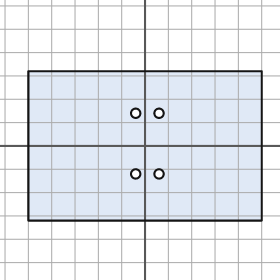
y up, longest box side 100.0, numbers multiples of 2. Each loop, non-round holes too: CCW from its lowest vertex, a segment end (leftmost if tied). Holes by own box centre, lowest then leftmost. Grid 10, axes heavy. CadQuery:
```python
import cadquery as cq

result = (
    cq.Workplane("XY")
    .moveTo(-50.0, -32.0)
    .lineTo(50.0, -32.0)
    .lineTo(50.0, 32.0)
    .lineTo(-50.0, 32.0)
    .close()
    .moveTo(-4.0, -12.0)
    .circle(2.0)
    .moveTo(6.0, -12.0)
    .circle(2.0)
    .moveTo(-4.0, 14.0)
    .circle(2.0)
    .moveTo(6.0, 14.0)
    .circle(2.0)
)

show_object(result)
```